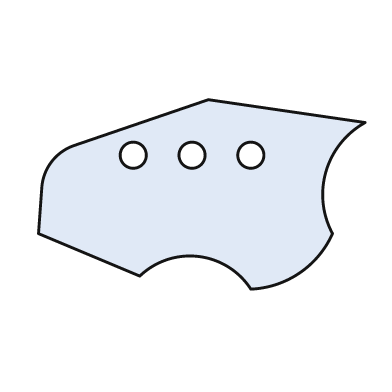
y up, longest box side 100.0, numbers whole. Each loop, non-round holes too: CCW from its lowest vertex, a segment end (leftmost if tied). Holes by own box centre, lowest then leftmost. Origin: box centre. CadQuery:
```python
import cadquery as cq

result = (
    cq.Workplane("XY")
    .moveTo(15.0, -29.0)
    .threePointArc((30.0, -24.0), (40.0, -12.0))
    .threePointArc((38.0, 7.0), (50.0, 22.0))
    .lineTo(2.0, 29.0)
    .lineTo(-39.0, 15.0)
    .threePointArc((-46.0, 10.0), (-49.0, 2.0))
    .lineTo(-50.0, -12.0)
    .lineTo(-19.0, -25.0)
    .threePointArc((-1.0, -19.0), (15.0, -29.0))
    .close()
    .moveTo(-21.0, 12.0)
    .circle(4.0)
    .moveTo(-3.0, 12.0)
    .circle(4.0)
    .moveTo(15.0, 12.0)
    .circle(4.0)
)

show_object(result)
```